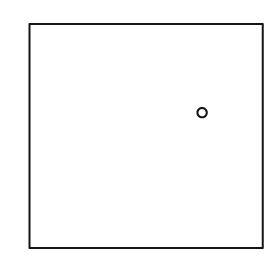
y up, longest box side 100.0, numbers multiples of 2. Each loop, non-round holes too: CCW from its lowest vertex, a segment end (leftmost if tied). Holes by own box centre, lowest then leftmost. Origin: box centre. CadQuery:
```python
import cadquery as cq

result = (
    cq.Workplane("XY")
    .moveTo(-50.0, -48.0)
    .lineTo(50.0, -48.0)
    .lineTo(50.0, 48.0)
    .lineTo(-50.0, 48.0)
    .close()
    .moveTo(24.0, 10.0)
    .circle(2.0)
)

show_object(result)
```